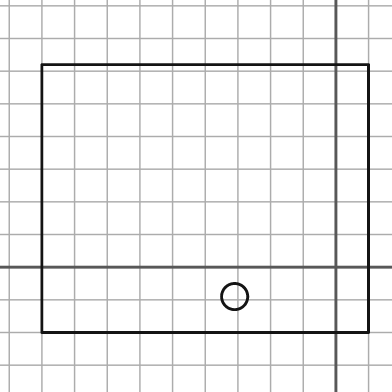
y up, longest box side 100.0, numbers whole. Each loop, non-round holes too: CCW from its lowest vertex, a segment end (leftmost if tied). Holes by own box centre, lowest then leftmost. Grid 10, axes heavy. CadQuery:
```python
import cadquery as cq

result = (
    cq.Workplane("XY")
    .moveTo(-90.0, -20.0)
    .lineTo(10.0, -20.0)
    .lineTo(10.0, 62.0)
    .lineTo(-90.0, 62.0)
    .close()
    .moveTo(-31.0, -9.0)
    .circle(4.0)
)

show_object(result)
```